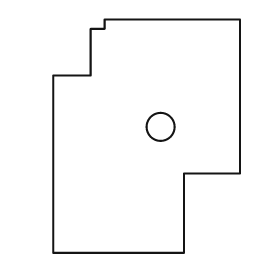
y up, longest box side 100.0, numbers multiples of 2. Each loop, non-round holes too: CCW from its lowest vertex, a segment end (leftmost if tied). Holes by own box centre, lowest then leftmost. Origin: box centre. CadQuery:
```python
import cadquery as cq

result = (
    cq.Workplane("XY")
    .moveTo(-40.0, -50.0)
    .lineTo(16.0, -50.0)
    .lineTo(16.0, -16.0)
    .lineTo(40.0, -16.0)
    .lineTo(40.0, 50.0)
    .lineTo(-18.0, 50.0)
    .lineTo(-18.0, 46.0)
    .lineTo(-24.0, 46.0)
    .lineTo(-24.0, 26.0)
    .lineTo(-40.0, 26.0)
    .close()
    .moveTo(6.0, 4.0)
    .circle(6.0)
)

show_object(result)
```